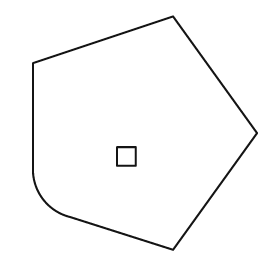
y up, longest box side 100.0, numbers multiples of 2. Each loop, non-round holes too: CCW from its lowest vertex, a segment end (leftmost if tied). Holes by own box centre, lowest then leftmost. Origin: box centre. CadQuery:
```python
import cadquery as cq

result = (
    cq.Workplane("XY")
    .moveTo(12.0, -50.0)
    .lineTo(48.0, 0.0)
    .lineTo(12.0, 50.0)
    .lineTo(-48.0, 30.0)
    .lineTo(-48.0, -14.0)
    .threePointArc((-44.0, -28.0), (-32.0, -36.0))
    .close()
    .moveTo(-12.0, -14.0)
    .lineTo(-4.0, -14.0)
    .lineTo(-4.0, -6.0)
    .lineTo(-12.0, -6.0)
    .close()
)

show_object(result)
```